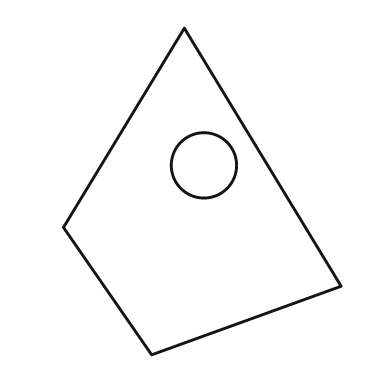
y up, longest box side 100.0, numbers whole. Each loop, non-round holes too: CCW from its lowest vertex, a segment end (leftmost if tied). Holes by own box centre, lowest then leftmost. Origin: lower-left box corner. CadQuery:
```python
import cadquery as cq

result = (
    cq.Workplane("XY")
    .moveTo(27.0, 0.0)
    .lineTo(85.0, 21.0)
    .lineTo(37.0, 100.0)
    .lineTo(0.0, 39.0)
    .close()
    .moveTo(43.0, 58.0)
    .circle(10.0)
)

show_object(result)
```